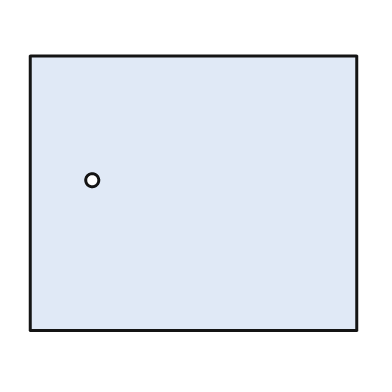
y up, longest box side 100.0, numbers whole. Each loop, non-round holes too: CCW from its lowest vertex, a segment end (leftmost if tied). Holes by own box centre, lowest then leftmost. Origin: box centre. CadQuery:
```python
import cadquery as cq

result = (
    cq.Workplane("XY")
    .moveTo(-50.0, -42.0)
    .lineTo(50.0, -42.0)
    .lineTo(50.0, 42.0)
    .lineTo(-50.0, 42.0)
    .close()
    .moveTo(-31.0, 4.0)
    .circle(2.0)
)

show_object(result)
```